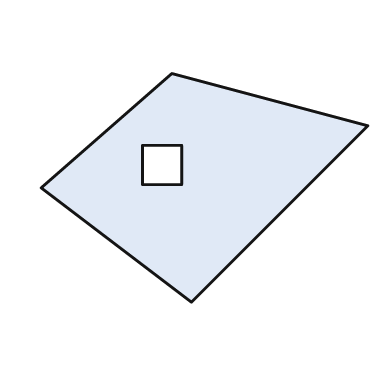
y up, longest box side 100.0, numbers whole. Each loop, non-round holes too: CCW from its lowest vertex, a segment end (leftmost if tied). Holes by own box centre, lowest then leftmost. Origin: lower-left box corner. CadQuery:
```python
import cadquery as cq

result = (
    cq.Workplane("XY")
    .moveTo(46.0, 0.0)
    .lineTo(100.0, 54.0)
    .lineTo(40.0, 70.0)
    .lineTo(0.0, 35.0)
    .close()
    .moveTo(31.0, 36.0)
    .lineTo(43.0, 36.0)
    .lineTo(43.0, 48.0)
    .lineTo(31.0, 48.0)
    .close()
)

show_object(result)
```